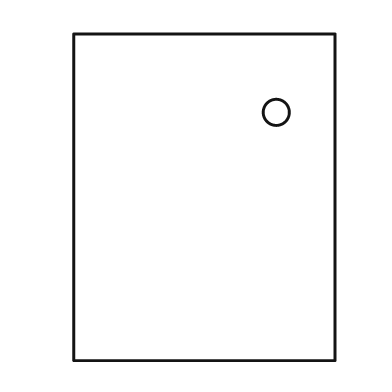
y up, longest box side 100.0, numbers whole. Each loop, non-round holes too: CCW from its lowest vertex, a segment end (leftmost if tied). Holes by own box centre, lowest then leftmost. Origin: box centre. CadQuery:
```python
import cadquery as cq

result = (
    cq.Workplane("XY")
    .moveTo(-40.0, -50.0)
    .lineTo(40.0, -50.0)
    .lineTo(40.0, 50.0)
    .lineTo(-40.0, 50.0)
    .close()
    .moveTo(22.0, 26.0)
    .circle(4.0)
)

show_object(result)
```